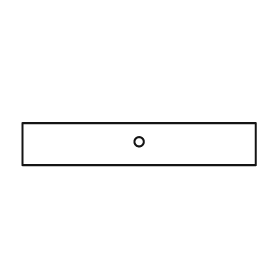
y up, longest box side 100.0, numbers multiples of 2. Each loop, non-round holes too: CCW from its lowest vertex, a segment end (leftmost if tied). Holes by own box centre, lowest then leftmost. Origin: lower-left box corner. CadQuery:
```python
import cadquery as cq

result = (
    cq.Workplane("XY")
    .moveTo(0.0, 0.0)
    .lineTo(100.0, 0.0)
    .lineTo(100.0, 18.0)
    .lineTo(0.0, 18.0)
    .close()
    .moveTo(50.0, 10.0)
    .circle(2.0)
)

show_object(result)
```